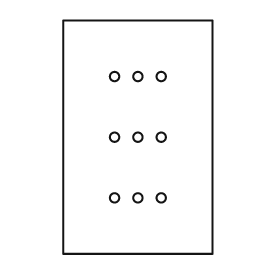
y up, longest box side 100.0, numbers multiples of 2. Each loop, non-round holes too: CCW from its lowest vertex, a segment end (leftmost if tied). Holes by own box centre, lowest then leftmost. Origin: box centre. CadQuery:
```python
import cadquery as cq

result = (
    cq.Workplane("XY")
    .moveTo(-32.0, -50.0)
    .lineTo(32.0, -50.0)
    .lineTo(32.0, 50.0)
    .lineTo(-32.0, 50.0)
    .close()
    .moveTo(-10.0, -26.0)
    .circle(2.0)
    .moveTo(0.0, -26.0)
    .circle(2.0)
    .moveTo(10.0, -26.0)
    .circle(2.0)
    .moveTo(-10.0, 0.0)
    .circle(2.0)
    .moveTo(0.0, 0.0)
    .circle(2.0)
    .moveTo(10.0, 0.0)
    .circle(2.0)
    .moveTo(-10.0, 26.0)
    .circle(2.0)
    .moveTo(0.0, 26.0)
    .circle(2.0)
    .moveTo(10.0, 26.0)
    .circle(2.0)
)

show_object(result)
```